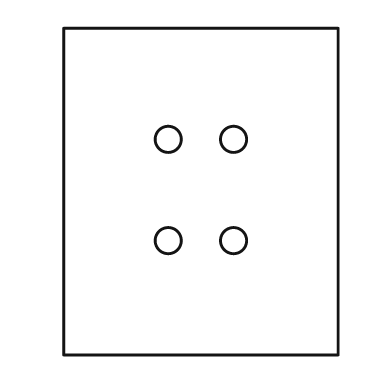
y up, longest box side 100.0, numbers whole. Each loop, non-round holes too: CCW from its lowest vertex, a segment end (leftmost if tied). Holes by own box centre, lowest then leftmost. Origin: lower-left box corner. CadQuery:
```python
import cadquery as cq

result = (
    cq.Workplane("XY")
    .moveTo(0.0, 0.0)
    .lineTo(84.0, 0.0)
    .lineTo(84.0, 100.0)
    .lineTo(0.0, 100.0)
    .close()
    .moveTo(32.0, 35.0)
    .circle(4.0)
    .moveTo(52.0, 35.0)
    .circle(4.0)
    .moveTo(32.0, 66.0)
    .circle(4.0)
    .moveTo(52.0, 66.0)
    .circle(4.0)
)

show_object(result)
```